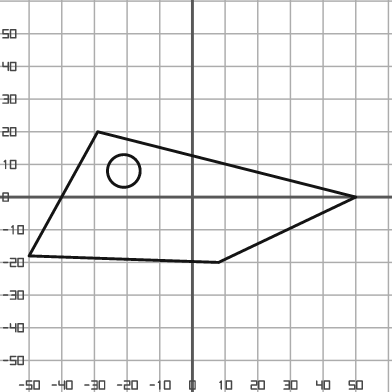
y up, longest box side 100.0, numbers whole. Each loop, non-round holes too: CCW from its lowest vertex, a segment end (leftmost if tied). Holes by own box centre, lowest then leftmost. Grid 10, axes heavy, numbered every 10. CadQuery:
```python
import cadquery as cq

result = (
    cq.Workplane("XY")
    .moveTo(8.0, -20.0)
    .lineTo(50.0, 0.0)
    .lineTo(-29.0, 20.0)
    .lineTo(-50.0, -18.0)
    .close()
    .moveTo(-21.0, 8.0)
    .circle(5.0)
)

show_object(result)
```